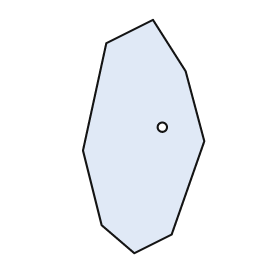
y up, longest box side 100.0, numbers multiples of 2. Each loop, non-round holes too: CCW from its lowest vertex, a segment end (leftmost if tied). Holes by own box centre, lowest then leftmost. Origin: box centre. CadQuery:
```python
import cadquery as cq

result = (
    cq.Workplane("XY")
    .moveTo(-4.0, -50.0)
    .lineTo(12.0, -42.0)
    .lineTo(26.0, -2.0)
    .lineTo(18.0, 28.0)
    .lineTo(4.0, 50.0)
    .lineTo(-16.0, 40.0)
    .lineTo(-26.0, -6.0)
    .lineTo(-18.0, -38.0)
    .close()
    .moveTo(8.0, 4.0)
    .circle(2.0)
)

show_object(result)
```